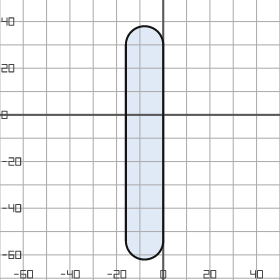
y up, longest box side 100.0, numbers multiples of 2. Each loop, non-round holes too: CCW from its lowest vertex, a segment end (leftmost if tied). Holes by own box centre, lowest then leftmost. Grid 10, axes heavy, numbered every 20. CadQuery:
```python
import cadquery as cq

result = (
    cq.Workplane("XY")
    .moveTo(-16.0, -54.0)
    .threePointArc((-8.0, -62.0), (0.0, -54.0))
    .lineTo(0.0, 30.0)
    .threePointArc((-8.0, 38.0), (-16.0, 30.0))
    .close()
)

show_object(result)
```